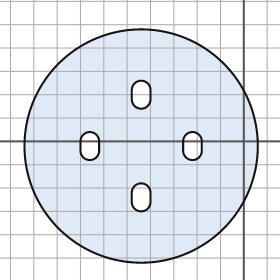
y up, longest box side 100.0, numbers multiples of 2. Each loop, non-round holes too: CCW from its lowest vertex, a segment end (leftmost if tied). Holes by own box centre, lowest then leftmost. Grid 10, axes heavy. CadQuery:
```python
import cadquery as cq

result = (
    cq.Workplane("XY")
    .moveTo(-44.0, -2.0)
    .circle(50.0)
    .moveTo(-48.0, -26.0)
    .threePointArc((-44.0, -30.0), (-40.0, -26.0))
    .lineTo(-40.0, -22.0)
    .threePointArc((-44.0, -18.0), (-48.0, -22.0))
    .close()
    .moveTo(-70.0, -4.0)
    .threePointArc((-66.0, -8.0), (-62.0, -4.0))
    .lineTo(-62.0, 0.0)
    .threePointArc((-66.0, 4.0), (-70.0, 0.0))
    .close()
    .moveTo(-26.0, -4.0)
    .threePointArc((-22.0, -8.0), (-18.0, -4.0))
    .lineTo(-18.0, 0.0)
    .threePointArc((-22.0, 4.0), (-26.0, 0.0))
    .close()
    .moveTo(-48.0, 18.0)
    .threePointArc((-44.0, 14.0), (-40.0, 18.0))
    .lineTo(-40.0, 22.0)
    .threePointArc((-44.0, 26.0), (-48.0, 22.0))
    .close()
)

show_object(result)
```